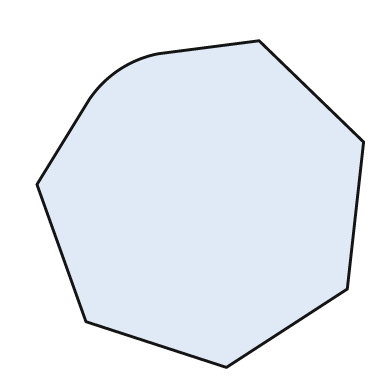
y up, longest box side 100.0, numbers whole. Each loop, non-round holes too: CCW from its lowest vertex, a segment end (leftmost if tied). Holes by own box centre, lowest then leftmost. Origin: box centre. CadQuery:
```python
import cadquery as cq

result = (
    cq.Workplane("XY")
    .moveTo(8.0, -50.0)
    .lineTo(45.0, -26.0)
    .lineTo(50.0, 19.0)
    .lineTo(18.0, 50.0)
    .lineTo(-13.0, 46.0)
    .threePointArc((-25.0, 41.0), (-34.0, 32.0))
    .lineTo(-50.0, 6.0)
    .lineTo(-35.0, -36.0)
    .close()
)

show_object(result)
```